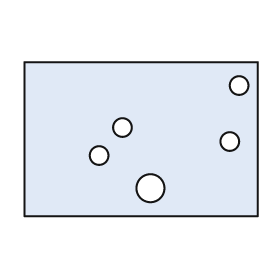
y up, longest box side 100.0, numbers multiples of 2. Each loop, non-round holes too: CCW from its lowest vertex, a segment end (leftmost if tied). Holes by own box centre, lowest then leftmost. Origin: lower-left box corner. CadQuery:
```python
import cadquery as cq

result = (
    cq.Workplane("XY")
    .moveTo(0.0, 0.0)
    .lineTo(100.0, 0.0)
    .lineTo(100.0, 66.0)
    .lineTo(0.0, 66.0)
    .close()
    .moveTo(54.0, 12.0)
    .circle(6.0)
    .moveTo(32.0, 26.0)
    .circle(4.0)
    .moveTo(88.0, 32.0)
    .circle(4.0)
    .moveTo(42.0, 38.0)
    .circle(4.0)
    .moveTo(92.0, 56.0)
    .circle(4.0)
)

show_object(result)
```